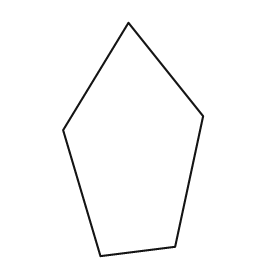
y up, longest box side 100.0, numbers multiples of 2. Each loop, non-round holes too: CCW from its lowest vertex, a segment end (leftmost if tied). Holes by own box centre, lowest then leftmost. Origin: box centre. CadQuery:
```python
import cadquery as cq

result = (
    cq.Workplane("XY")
    .moveTo(-14.0, -50.0)
    .lineTo(18.0, -46.0)
    .lineTo(30.0, 10.0)
    .lineTo(-2.0, 50.0)
    .lineTo(-30.0, 4.0)
    .close()
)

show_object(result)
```